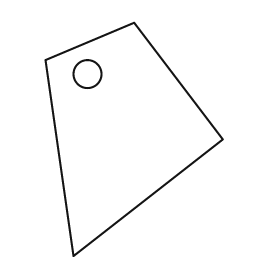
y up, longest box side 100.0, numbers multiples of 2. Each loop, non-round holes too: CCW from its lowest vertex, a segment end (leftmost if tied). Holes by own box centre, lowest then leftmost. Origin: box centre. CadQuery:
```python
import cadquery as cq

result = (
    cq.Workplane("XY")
    .moveTo(-26.0, -50.0)
    .lineTo(38.0, 0.0)
    .lineTo(0.0, 50.0)
    .lineTo(-38.0, 34.0)
    .close()
    .moveTo(-20.0, 28.0)
    .circle(6.0)
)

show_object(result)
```